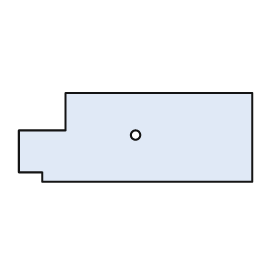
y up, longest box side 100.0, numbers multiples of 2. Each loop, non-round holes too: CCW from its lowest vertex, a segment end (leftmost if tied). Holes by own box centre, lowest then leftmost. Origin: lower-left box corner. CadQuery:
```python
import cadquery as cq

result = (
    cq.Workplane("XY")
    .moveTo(10.0, 0.0)
    .lineTo(100.0, 0.0)
    .lineTo(100.0, 38.0)
    .lineTo(20.0, 38.0)
    .lineTo(20.0, 22.0)
    .lineTo(0.0, 22.0)
    .lineTo(0.0, 4.0)
    .lineTo(10.0, 4.0)
    .close()
    .moveTo(50.0, 20.0)
    .circle(2.0)
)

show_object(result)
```